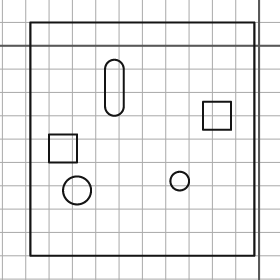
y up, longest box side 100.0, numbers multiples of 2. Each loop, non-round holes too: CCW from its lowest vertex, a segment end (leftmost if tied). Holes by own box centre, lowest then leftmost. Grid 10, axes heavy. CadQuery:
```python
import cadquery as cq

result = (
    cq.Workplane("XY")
    .moveTo(-98.0, -90.0)
    .lineTo(-2.0, -90.0)
    .lineTo(-2.0, 10.0)
    .lineTo(-98.0, 10.0)
    .close()
    .moveTo(-78.0, -62.0)
    .circle(6.0)
    .moveTo(-34.0, -58.0)
    .circle(4.0)
    .moveTo(-90.0, -50.0)
    .lineTo(-78.0, -50.0)
    .lineTo(-78.0, -38.0)
    .lineTo(-90.0, -38.0)
    .close()
    .moveTo(-24.0, -36.0)
    .lineTo(-12.0, -36.0)
    .lineTo(-12.0, -24.0)
    .lineTo(-24.0, -24.0)
    .close()
    .moveTo(-66.0, -26.0)
    .threePointArc((-62.0, -30.0), (-58.0, -26.0))
    .lineTo(-58.0, -10.0)
    .threePointArc((-62.0, -6.0), (-66.0, -10.0))
    .close()
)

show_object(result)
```